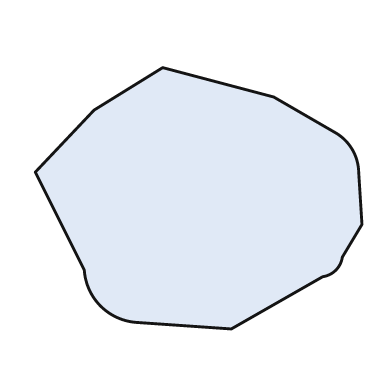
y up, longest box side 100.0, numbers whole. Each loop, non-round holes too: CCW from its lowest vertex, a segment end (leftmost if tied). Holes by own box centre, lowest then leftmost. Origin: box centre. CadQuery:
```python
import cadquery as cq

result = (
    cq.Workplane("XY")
    .moveTo(10.0, -40.0)
    .lineTo(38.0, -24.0)
    .threePointArc((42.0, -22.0), (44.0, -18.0))
    .lineTo(50.0, -8.0)
    .lineTo(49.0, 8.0)
    .threePointArc((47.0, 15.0), (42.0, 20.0))
    .lineTo(23.0, 31.0)
    .lineTo(-11.0, 40.0)
    .lineTo(-32.0, 27.0)
    .lineTo(-50.0, 8.0)
    .lineTo(-35.0, -22.0)
    .threePointArc((-30.0, -33.0), (-19.0, -38.0))
    .close()
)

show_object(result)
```